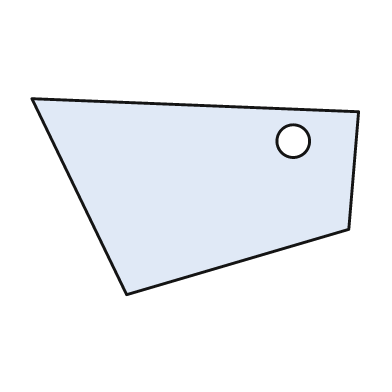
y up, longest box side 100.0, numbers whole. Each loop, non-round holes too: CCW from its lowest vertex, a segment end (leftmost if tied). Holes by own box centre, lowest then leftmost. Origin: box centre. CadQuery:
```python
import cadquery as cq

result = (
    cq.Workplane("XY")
    .moveTo(-21.0, -30.0)
    .lineTo(47.0, -10.0)
    .lineTo(50.0, 26.0)
    .lineTo(-50.0, 30.0)
    .close()
    .moveTo(30.0, 17.0)
    .circle(5.0)
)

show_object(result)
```